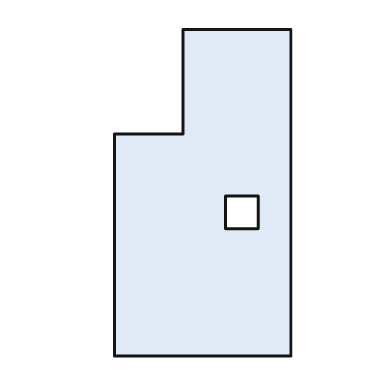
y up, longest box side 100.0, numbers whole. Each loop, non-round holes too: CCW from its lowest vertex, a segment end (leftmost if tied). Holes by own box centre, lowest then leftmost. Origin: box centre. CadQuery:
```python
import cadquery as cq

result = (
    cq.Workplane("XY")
    .moveTo(-27.0, -50.0)
    .lineTo(27.0, -50.0)
    .lineTo(27.0, 50.0)
    .lineTo(-6.0, 50.0)
    .lineTo(-6.0, 18.0)
    .lineTo(-27.0, 18.0)
    .close()
    .moveTo(7.0, -11.0)
    .lineTo(17.0, -11.0)
    .lineTo(17.0, -1.0)
    .lineTo(7.0, -1.0)
    .close()
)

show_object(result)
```